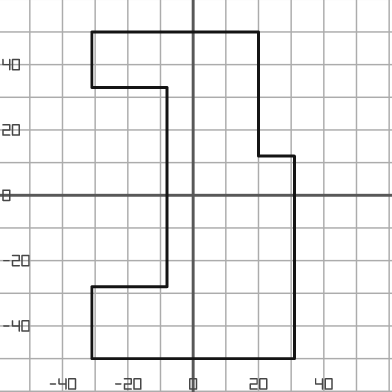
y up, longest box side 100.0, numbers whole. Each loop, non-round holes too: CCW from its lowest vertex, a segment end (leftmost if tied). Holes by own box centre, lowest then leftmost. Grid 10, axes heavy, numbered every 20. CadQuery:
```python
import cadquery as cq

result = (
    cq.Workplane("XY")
    .moveTo(-31.0, -50.0)
    .lineTo(31.0, -50.0)
    .lineTo(31.0, 12.0)
    .lineTo(20.0, 12.0)
    .lineTo(20.0, 50.0)
    .lineTo(-31.0, 50.0)
    .lineTo(-31.0, 33.0)
    .lineTo(-8.0, 33.0)
    .lineTo(-8.0, -28.0)
    .lineTo(-31.0, -28.0)
    .close()
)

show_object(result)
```